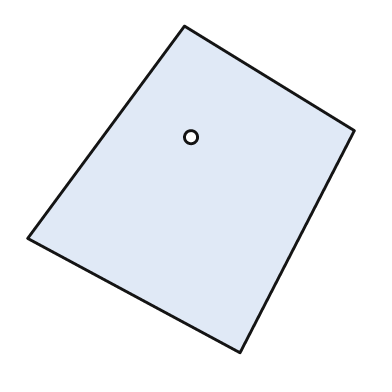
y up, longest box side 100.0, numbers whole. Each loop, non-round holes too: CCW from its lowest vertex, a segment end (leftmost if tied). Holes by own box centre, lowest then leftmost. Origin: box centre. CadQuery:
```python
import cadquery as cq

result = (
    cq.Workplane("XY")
    .moveTo(15.0, -50.0)
    .lineTo(50.0, 18.0)
    .lineTo(-2.0, 50.0)
    .lineTo(-50.0, -15.0)
    .close()
    .moveTo(0.0, 16.0)
    .circle(2.0)
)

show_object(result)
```